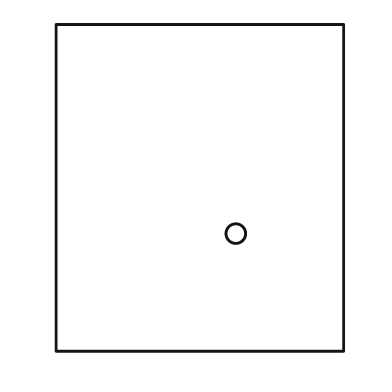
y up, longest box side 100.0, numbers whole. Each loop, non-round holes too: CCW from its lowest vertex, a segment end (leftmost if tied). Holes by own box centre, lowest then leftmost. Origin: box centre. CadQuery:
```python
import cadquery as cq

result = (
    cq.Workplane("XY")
    .moveTo(-44.0, -50.0)
    .lineTo(44.0, -50.0)
    .lineTo(44.0, 50.0)
    .lineTo(-44.0, 50.0)
    .close()
    .moveTo(11.0, -14.0)
    .circle(3.0)
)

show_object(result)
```